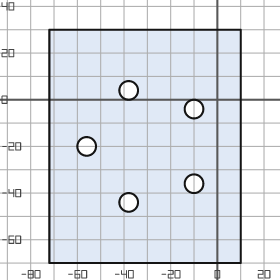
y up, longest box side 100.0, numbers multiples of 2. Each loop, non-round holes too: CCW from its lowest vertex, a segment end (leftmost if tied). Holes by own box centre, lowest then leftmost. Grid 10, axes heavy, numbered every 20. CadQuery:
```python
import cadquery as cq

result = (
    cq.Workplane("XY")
    .moveTo(-72.0, -70.0)
    .lineTo(10.0, -70.0)
    .lineTo(10.0, 30.0)
    .lineTo(-72.0, 30.0)
    .close()
    .moveTo(-38.0, -44.0)
    .circle(4.0)
    .moveTo(-10.0, -36.0)
    .circle(4.0)
    .moveTo(-56.0, -20.0)
    .circle(4.0)
    .moveTo(-10.0, -4.0)
    .circle(4.0)
    .moveTo(-38.0, 4.0)
    .circle(4.0)
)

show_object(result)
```